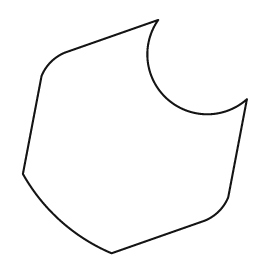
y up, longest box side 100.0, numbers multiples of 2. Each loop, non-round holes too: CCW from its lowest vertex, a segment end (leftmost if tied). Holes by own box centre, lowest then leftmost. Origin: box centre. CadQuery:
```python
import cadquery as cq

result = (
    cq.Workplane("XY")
    .moveTo(-10.0, -50.0)
    .lineTo(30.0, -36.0)
    .threePointArc((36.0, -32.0), (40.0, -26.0))
    .lineTo(48.0, 16.0)
    .threePointArc((14.0, 16.0), (10.0, 50.0))
    .lineTo(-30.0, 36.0)
    .threePointArc((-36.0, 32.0), (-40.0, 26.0))
    .lineTo(-48.0, -16.0)
    .threePointArc((-32.0, -36.0), (-10.0, -50.0))
    .close()
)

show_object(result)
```